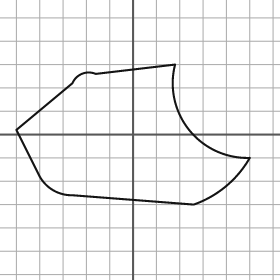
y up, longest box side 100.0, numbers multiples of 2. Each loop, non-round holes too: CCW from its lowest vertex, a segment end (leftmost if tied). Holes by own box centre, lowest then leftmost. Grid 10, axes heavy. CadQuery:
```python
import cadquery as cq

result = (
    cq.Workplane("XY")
    .moveTo(26.0, -30.0)
    .threePointArc((40.0, -22.0), (50.0, -10.0))
    .threePointArc((24.0, 2.0), (18.0, 30.0))
    .lineTo(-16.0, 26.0)
    .threePointArc((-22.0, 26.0), (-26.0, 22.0))
    .lineTo(-50.0, 2.0)
    .lineTo(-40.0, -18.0)
    .threePointArc((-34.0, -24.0), (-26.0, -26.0))
    .close()
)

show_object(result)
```